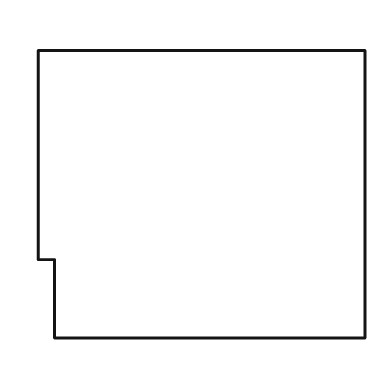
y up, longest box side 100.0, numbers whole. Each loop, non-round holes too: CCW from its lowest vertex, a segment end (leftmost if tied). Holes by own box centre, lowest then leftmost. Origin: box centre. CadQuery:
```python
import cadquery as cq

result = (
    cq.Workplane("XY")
    .moveTo(-45.0, -44.0)
    .lineTo(50.0, -44.0)
    .lineTo(50.0, 44.0)
    .lineTo(-50.0, 44.0)
    .lineTo(-50.0, -20.0)
    .lineTo(-45.0, -20.0)
    .close()
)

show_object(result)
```